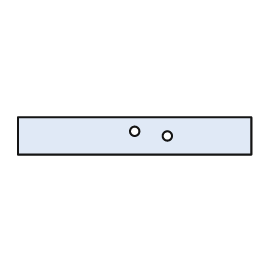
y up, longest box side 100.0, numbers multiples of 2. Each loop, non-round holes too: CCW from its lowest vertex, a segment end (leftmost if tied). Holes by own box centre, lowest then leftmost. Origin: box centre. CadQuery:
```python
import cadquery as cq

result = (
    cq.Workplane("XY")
    .moveTo(-50.0, -8.0)
    .lineTo(50.0, -8.0)
    .lineTo(50.0, 8.0)
    .lineTo(-50.0, 8.0)
    .close()
    .moveTo(14.0, 0.0)
    .circle(2.0)
    .moveTo(0.0, 2.0)
    .circle(2.0)
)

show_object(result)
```